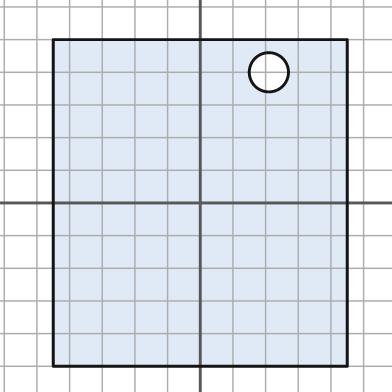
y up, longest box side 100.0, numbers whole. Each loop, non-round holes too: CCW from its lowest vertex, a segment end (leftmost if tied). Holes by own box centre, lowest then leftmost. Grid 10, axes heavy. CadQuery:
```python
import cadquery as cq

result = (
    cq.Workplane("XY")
    .moveTo(-45.0, -50.0)
    .lineTo(45.0, -50.0)
    .lineTo(45.0, 50.0)
    .lineTo(-45.0, 50.0)
    .close()
    .moveTo(21.0, 40.0)
    .circle(6.0)
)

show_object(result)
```